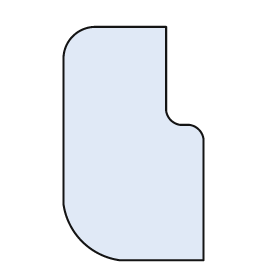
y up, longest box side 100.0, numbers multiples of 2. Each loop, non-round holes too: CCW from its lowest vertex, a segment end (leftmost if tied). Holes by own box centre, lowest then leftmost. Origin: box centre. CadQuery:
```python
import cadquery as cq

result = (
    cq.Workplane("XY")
    .moveTo(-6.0, -50.0)
    .lineTo(30.0, -50.0)
    .lineTo(30.0, 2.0)
    .threePointArc((28.0, 6.0), (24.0, 8.0))
    .lineTo(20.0, 8.0)
    .threePointArc((16.0, 10.0), (14.0, 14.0))
    .lineTo(14.0, 50.0)
    .lineTo(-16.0, 50.0)
    .threePointArc((-26.0, 46.0), (-30.0, 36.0))
    .lineTo(-30.0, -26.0)
    .threePointArc((-22.0, -42.0), (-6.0, -50.0))
    .close()
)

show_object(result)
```